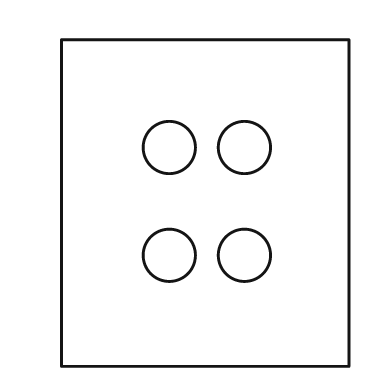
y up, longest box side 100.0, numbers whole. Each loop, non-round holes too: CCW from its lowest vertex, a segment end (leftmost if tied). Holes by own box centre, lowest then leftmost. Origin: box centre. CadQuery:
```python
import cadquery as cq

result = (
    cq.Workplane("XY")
    .moveTo(-44.0, -50.0)
    .lineTo(44.0, -50.0)
    .lineTo(44.0, 50.0)
    .lineTo(-44.0, 50.0)
    .close()
    .moveTo(-11.0, -16.0)
    .circle(8.0)
    .moveTo(12.0, -16.0)
    .circle(8.0)
    .moveTo(-11.0, 17.0)
    .circle(8.0)
    .moveTo(12.0, 17.0)
    .circle(8.0)
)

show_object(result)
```